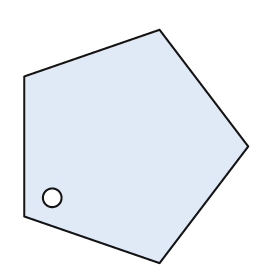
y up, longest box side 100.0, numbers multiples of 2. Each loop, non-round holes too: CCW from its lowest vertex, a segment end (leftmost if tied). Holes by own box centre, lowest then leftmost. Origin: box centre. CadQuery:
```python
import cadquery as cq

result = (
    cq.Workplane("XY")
    .moveTo(10.0, -50.0)
    .lineTo(48.0, 0.0)
    .lineTo(10.0, 50.0)
    .lineTo(-48.0, 30.0)
    .lineTo(-48.0, -30.0)
    .close()
    .moveTo(-36.0, -22.0)
    .circle(4.0)
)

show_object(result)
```